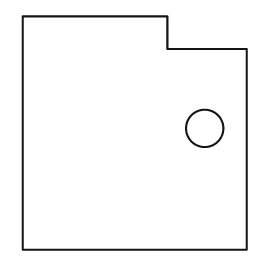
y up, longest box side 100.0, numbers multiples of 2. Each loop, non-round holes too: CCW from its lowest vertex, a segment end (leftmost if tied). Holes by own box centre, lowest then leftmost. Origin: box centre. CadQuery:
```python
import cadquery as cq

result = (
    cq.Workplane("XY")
    .moveTo(-48.0, -50.0)
    .lineTo(48.0, -50.0)
    .lineTo(48.0, 36.0)
    .lineTo(14.0, 36.0)
    .lineTo(14.0, 50.0)
    .lineTo(-48.0, 50.0)
    .close()
    .moveTo(30.0, 2.0)
    .circle(8.0)
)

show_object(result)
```